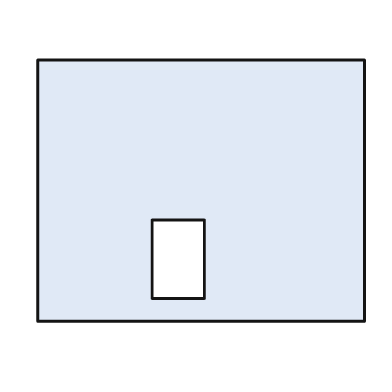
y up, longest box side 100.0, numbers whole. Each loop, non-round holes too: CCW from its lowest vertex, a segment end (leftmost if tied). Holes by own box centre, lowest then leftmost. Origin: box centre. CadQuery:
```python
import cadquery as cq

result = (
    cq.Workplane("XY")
    .moveTo(-50.0, -40.0)
    .lineTo(50.0, -40.0)
    .lineTo(50.0, 40.0)
    .lineTo(-50.0, 40.0)
    .close()
    .moveTo(-15.0, -33.0)
    .lineTo(1.0, -33.0)
    .lineTo(1.0, -9.0)
    .lineTo(-15.0, -9.0)
    .close()
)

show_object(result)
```